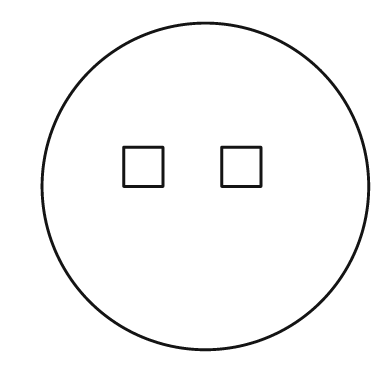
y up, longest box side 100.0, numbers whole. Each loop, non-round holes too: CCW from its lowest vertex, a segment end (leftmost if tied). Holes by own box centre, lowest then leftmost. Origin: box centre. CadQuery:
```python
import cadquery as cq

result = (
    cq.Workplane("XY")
    .moveTo(0.0, 0.0)
    .circle(50.0)
    .moveTo(-25.0, 0.0)
    .lineTo(-13.0, 0.0)
    .lineTo(-13.0, 12.0)
    .lineTo(-25.0, 12.0)
    .close()
    .moveTo(5.0, 0.0)
    .lineTo(17.0, 0.0)
    .lineTo(17.0, 12.0)
    .lineTo(5.0, 12.0)
    .close()
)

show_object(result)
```